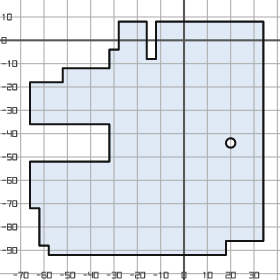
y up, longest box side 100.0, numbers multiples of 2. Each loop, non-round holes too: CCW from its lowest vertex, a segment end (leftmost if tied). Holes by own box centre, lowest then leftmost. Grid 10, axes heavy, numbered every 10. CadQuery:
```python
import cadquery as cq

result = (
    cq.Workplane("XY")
    .moveTo(-58.0, -92.0)
    .lineTo(18.0, -92.0)
    .lineTo(18.0, -86.0)
    .lineTo(34.0, -86.0)
    .lineTo(34.0, 8.0)
    .lineTo(-12.0, 8.0)
    .lineTo(-12.0, -8.0)
    .lineTo(-16.0, -8.0)
    .lineTo(-16.0, 8.0)
    .lineTo(-28.0, 8.0)
    .lineTo(-28.0, -4.0)
    .lineTo(-32.0, -4.0)
    .lineTo(-32.0, -12.0)
    .lineTo(-52.0, -12.0)
    .lineTo(-52.0, -18.0)
    .lineTo(-66.0, -18.0)
    .lineTo(-66.0, -36.0)
    .lineTo(-32.0, -36.0)
    .lineTo(-32.0, -52.0)
    .lineTo(-66.0, -52.0)
    .lineTo(-66.0, -72.0)
    .lineTo(-62.0, -72.0)
    .lineTo(-62.0, -88.0)
    .lineTo(-58.0, -88.0)
    .close()
    .moveTo(20.0, -44.0)
    .circle(2.0)
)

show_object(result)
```